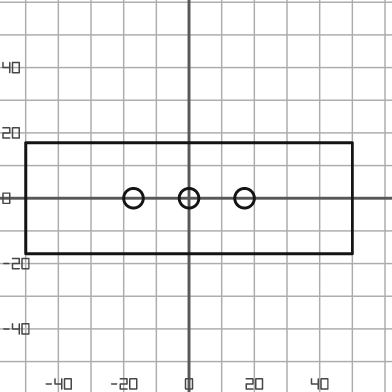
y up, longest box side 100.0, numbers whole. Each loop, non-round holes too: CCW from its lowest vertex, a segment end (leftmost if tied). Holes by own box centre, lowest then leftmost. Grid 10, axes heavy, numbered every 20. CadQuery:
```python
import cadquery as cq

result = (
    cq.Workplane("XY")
    .moveTo(-50.0, -17.0)
    .lineTo(50.0, -17.0)
    .lineTo(50.0, 17.0)
    .lineTo(-50.0, 17.0)
    .close()
    .moveTo(-17.0, 0.0)
    .circle(3.0)
    .moveTo(0.0, 0.0)
    .circle(3.0)
    .moveTo(17.0, 0.0)
    .circle(3.0)
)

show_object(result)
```